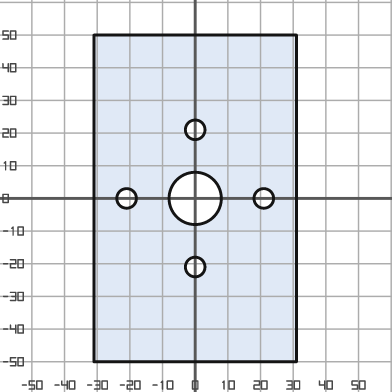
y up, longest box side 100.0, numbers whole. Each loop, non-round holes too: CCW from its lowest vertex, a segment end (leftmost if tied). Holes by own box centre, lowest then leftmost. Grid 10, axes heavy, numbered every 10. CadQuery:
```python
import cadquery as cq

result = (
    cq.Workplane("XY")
    .moveTo(-31.0, -50.0)
    .lineTo(31.0, -50.0)
    .lineTo(31.0, 50.0)
    .lineTo(-31.0, 50.0)
    .close()
    .moveTo(0.0, -21.0)
    .circle(3.0)
    .moveTo(-21.0, 0.0)
    .circle(3.0)
    .moveTo(0.0, 0.0)
    .circle(8.0)
    .moveTo(21.0, 0.0)
    .circle(3.0)
    .moveTo(0.0, 21.0)
    .circle(3.0)
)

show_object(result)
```